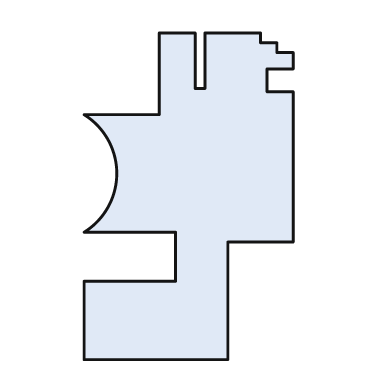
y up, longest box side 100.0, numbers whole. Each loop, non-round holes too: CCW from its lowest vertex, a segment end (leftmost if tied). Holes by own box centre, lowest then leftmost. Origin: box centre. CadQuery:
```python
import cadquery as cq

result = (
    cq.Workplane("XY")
    .moveTo(-32.0, -50.0)
    .lineTo(12.0, -50.0)
    .lineTo(12.0, -14.0)
    .lineTo(32.0, -14.0)
    .lineTo(32.0, 32.0)
    .lineTo(24.0, 32.0)
    .lineTo(24.0, 39.0)
    .lineTo(32.0, 39.0)
    .lineTo(32.0, 44.0)
    .lineTo(27.0, 44.0)
    .lineTo(27.0, 47.0)
    .lineTo(22.0, 47.0)
    .lineTo(22.0, 50.0)
    .lineTo(5.0, 50.0)
    .lineTo(5.0, 33.0)
    .lineTo(2.0, 33.0)
    .lineTo(2.0, 50.0)
    .lineTo(-9.0, 50.0)
    .lineTo(-9.0, 25.0)
    .lineTo(-32.0, 25.0)
    .threePointArc((-22.0, 7.0), (-32.0, -11.0))
    .lineTo(-4.0, -11.0)
    .lineTo(-4.0, -26.0)
    .lineTo(-32.0, -26.0)
    .close()
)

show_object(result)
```